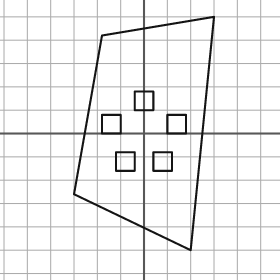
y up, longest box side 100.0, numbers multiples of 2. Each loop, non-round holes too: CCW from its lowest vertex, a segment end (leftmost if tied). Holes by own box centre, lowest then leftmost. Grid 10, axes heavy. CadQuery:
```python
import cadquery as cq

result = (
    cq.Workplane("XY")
    .moveTo(20.0, -50.0)
    .lineTo(30.0, 50.0)
    .lineTo(-18.0, 42.0)
    .lineTo(-30.0, -26.0)
    .close()
    .moveTo(-12.0, -16.0)
    .lineTo(-4.0, -16.0)
    .lineTo(-4.0, -8.0)
    .lineTo(-12.0, -8.0)
    .close()
    .moveTo(4.0, -16.0)
    .lineTo(12.0, -16.0)
    .lineTo(12.0, -8.0)
    .lineTo(4.0, -8.0)
    .close()
    .moveTo(-18.0, 0.0)
    .lineTo(-10.0, 0.0)
    .lineTo(-10.0, 8.0)
    .lineTo(-18.0, 8.0)
    .close()
    .moveTo(10.0, 0.0)
    .lineTo(18.0, 0.0)
    .lineTo(18.0, 8.0)
    .lineTo(10.0, 8.0)
    .close()
    .moveTo(-4.0, 10.0)
    .lineTo(4.0, 10.0)
    .lineTo(4.0, 18.0)
    .lineTo(-4.0, 18.0)
    .close()
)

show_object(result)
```